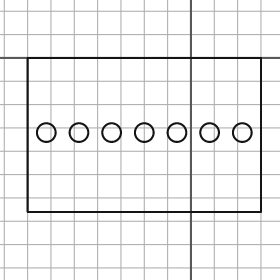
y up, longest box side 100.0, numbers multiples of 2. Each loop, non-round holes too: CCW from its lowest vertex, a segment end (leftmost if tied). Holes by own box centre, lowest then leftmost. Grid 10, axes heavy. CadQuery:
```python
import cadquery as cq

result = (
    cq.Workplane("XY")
    .moveTo(-70.0, -66.0)
    .lineTo(30.0, -66.0)
    .lineTo(30.0, 0.0)
    .lineTo(-70.0, 0.0)
    .close()
    .moveTo(-62.0, -32.0)
    .circle(4.0)
    .moveTo(-48.0, -32.0)
    .circle(4.0)
    .moveTo(-34.0, -32.0)
    .circle(4.0)
    .moveTo(-20.0, -32.0)
    .circle(4.0)
    .moveTo(-6.0, -32.0)
    .circle(4.0)
    .moveTo(8.0, -32.0)
    .circle(4.0)
    .moveTo(22.0, -32.0)
    .circle(4.0)
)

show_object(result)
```